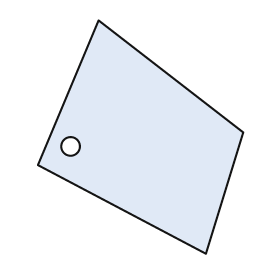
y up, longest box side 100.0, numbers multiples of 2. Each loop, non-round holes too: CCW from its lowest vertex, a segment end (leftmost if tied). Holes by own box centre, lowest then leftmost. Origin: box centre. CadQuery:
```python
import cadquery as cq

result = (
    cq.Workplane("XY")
    .moveTo(28.0, -50.0)
    .lineTo(44.0, 2.0)
    .lineTo(-18.0, 50.0)
    .lineTo(-44.0, -12.0)
    .close()
    .moveTo(-30.0, -4.0)
    .circle(4.0)
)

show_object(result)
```